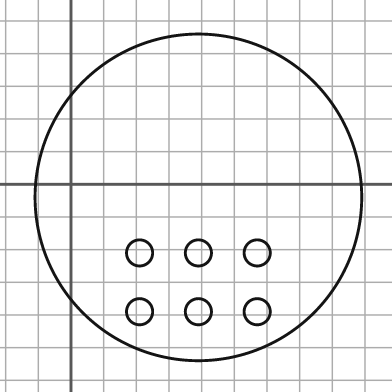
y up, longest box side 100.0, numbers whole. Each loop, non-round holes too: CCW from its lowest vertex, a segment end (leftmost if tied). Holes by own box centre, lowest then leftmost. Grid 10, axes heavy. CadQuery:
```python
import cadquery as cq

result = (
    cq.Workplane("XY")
    .moveTo(39.0, -4.0)
    .circle(50.0)
    .moveTo(21.0, -39.0)
    .circle(4.0)
    .moveTo(39.0, -39.0)
    .circle(4.0)
    .moveTo(57.0, -39.0)
    .circle(4.0)
    .moveTo(21.0, -21.0)
    .circle(4.0)
    .moveTo(39.0, -21.0)
    .circle(4.0)
    .moveTo(57.0, -21.0)
    .circle(4.0)
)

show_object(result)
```